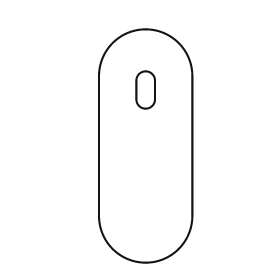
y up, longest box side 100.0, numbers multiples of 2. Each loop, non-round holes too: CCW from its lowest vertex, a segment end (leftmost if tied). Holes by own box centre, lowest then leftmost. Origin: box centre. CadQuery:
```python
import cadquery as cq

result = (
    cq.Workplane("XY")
    .moveTo(-20.0, -30.0)
    .threePointArc((0.0, -50.0), (20.0, -30.0))
    .lineTo(20.0, 30.0)
    .threePointArc((0.0, 50.0), (-20.0, 30.0))
    .close()
    .moveTo(-4.0, 20.0)
    .threePointArc((0.0, 16.0), (4.0, 20.0))
    .lineTo(4.0, 28.0)
    .threePointArc((0.0, 32.0), (-4.0, 28.0))
    .close()
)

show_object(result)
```